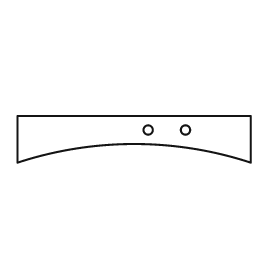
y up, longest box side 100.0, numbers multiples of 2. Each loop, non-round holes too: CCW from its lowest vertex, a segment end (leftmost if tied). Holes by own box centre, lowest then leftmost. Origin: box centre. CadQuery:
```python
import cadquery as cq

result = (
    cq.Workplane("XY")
    .moveTo(-50.0, -10.0)
    .threePointArc((0.0, -2.0), (50.0, -10.0))
    .lineTo(50.0, 10.0)
    .lineTo(-50.0, 10.0)
    .close()
    .moveTo(6.0, 4.0)
    .circle(2.0)
    .moveTo(22.0, 4.0)
    .circle(2.0)
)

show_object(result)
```